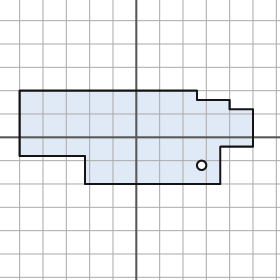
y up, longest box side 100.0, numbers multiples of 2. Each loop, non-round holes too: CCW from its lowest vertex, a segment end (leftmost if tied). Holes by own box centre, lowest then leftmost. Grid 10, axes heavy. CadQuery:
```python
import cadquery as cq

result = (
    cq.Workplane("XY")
    .moveTo(-22.0, -20.0)
    .lineTo(36.0, -20.0)
    .lineTo(36.0, -4.0)
    .lineTo(50.0, -4.0)
    .lineTo(50.0, 12.0)
    .lineTo(40.0, 12.0)
    .lineTo(40.0, 16.0)
    .lineTo(26.0, 16.0)
    .lineTo(26.0, 20.0)
    .lineTo(-50.0, 20.0)
    .lineTo(-50.0, -8.0)
    .lineTo(-22.0, -8.0)
    .close()
    .moveTo(28.0, -12.0)
    .circle(2.0)
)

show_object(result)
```